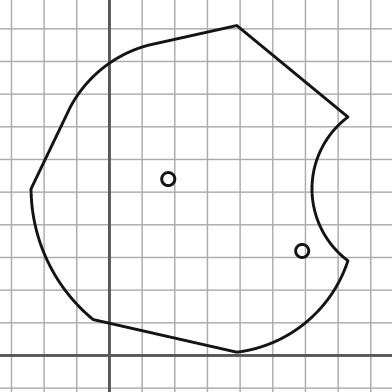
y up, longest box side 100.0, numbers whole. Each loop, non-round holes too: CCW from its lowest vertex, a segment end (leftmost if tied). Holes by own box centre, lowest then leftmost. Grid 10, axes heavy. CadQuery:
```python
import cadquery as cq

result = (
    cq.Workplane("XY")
    .moveTo(39.0, 1.0)
    .threePointArc((60.0, 10.0), (73.0, 29.0))
    .threePointArc((62.0, 51.0), (73.0, 73.0))
    .lineTo(39.0, 101.0)
    .lineTo(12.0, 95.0)
    .threePointArc((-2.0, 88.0), (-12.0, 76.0))
    .lineTo(-24.0, 51.0)
    .threePointArc((-19.0, 29.0), (-5.0, 11.0))
    .close()
    .moveTo(59.0, 32.0)
    .circle(2.0)
    .moveTo(18.0, 54.0)
    .circle(2.0)
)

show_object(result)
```